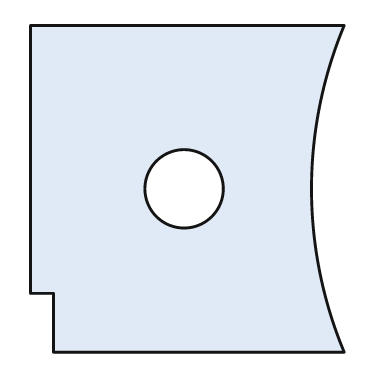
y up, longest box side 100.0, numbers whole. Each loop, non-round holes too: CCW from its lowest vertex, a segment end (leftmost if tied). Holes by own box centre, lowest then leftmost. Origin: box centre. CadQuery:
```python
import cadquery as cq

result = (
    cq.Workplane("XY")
    .moveTo(-41.0, -50.0)
    .lineTo(48.0, -50.0)
    .threePointArc((38.0, 0.0), (48.0, 50.0))
    .lineTo(-48.0, 50.0)
    .lineTo(-48.0, -32.0)
    .lineTo(-41.0, -32.0)
    .close()
    .moveTo(-1.0, 0.0)
    .circle(12.0)
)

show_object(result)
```